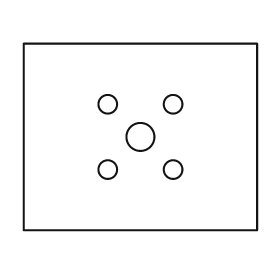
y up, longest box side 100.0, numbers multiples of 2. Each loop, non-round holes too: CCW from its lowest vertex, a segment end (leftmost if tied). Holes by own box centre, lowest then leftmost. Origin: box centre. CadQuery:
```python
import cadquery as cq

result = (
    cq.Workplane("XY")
    .moveTo(-50.0, -40.0)
    .lineTo(50.0, -40.0)
    .lineTo(50.0, 40.0)
    .lineTo(-50.0, 40.0)
    .close()
    .moveTo(-14.0, -14.0)
    .circle(4.0)
    .moveTo(14.0, -14.0)
    .circle(4.0)
    .moveTo(0.0, 0.0)
    .circle(6.0)
    .moveTo(-14.0, 14.0)
    .circle(4.0)
    .moveTo(14.0, 14.0)
    .circle(4.0)
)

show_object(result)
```